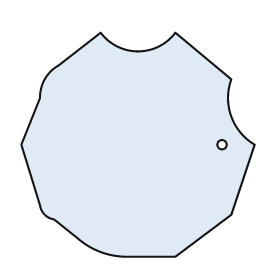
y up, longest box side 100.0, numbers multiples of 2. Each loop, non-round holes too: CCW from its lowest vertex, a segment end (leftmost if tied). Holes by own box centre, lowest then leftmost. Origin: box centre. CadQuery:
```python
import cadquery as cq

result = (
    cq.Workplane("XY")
    .moveTo(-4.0, -48.0)
    .lineTo(16.0, -48.0)
    .lineTo(40.0, -30.0)
    .lineTo(50.0, 0.0)
    .threePointArc((40.0, 12.0), (40.0, 28.0))
    .lineTo(16.0, 48.0)
    .threePointArc((0.0, 40.0), (-16.0, 48.0))
    .lineTo(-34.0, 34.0)
    .threePointArc((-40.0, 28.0), (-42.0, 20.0))
    .lineTo(-50.0, 0.0)
    .lineTo(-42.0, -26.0)
    .threePointArc((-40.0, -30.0), (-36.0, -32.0))
    .lineTo(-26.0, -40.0)
    .threePointArc((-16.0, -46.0), (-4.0, -48.0))
    .close()
    .moveTo(36.0, 0.0)
    .circle(2.0)
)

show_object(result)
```